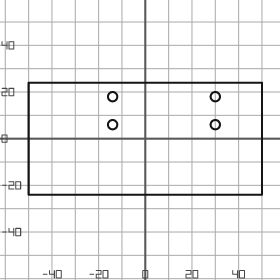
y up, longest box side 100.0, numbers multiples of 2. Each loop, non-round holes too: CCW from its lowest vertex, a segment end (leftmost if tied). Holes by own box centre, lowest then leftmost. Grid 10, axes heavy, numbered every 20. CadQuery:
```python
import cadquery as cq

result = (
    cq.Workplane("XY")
    .moveTo(-50.0, -24.0)
    .lineTo(50.0, -24.0)
    .lineTo(50.0, 24.0)
    .lineTo(-50.0, 24.0)
    .close()
    .moveTo(-14.0, 6.0)
    .circle(2.0)
    .moveTo(30.0, 6.0)
    .circle(2.0)
    .moveTo(-14.0, 18.0)
    .circle(2.0)
    .moveTo(30.0, 18.0)
    .circle(2.0)
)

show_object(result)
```